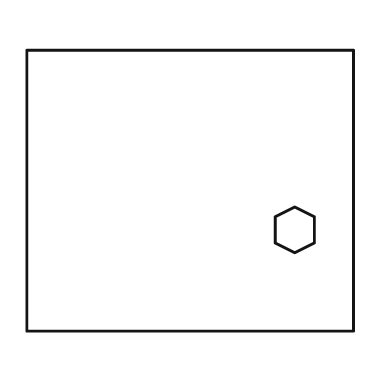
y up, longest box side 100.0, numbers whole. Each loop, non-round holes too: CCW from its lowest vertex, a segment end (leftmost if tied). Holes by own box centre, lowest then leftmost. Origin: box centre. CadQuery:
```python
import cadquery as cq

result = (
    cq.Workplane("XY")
    .moveTo(-50.0, -43.0)
    .lineTo(50.0, -43.0)
    .lineTo(50.0, 43.0)
    .lineTo(-50.0, 43.0)
    .close()
    .moveTo(32.0, -19.0)
    .lineTo(38.0, -16.0)
    .lineTo(38.0, -8.0)
    .lineTo(32.0, -5.0)
    .lineTo(26.0, -8.0)
    .lineTo(26.0, -16.0)
    .close()
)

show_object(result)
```